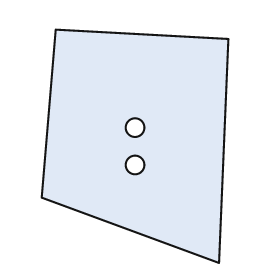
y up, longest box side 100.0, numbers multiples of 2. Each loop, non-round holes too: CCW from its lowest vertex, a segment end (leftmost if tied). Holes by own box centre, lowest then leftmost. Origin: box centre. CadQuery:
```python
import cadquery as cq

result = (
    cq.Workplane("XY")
    .moveTo(36.0, -50.0)
    .lineTo(40.0, 46.0)
    .lineTo(-34.0, 50.0)
    .lineTo(-40.0, -22.0)
    .close()
    .moveTo(0.0, -8.0)
    .circle(4.0)
    .moveTo(0.0, 8.0)
    .circle(4.0)
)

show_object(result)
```